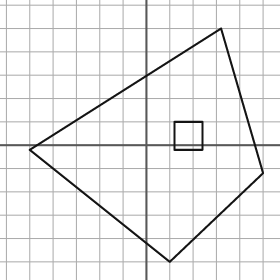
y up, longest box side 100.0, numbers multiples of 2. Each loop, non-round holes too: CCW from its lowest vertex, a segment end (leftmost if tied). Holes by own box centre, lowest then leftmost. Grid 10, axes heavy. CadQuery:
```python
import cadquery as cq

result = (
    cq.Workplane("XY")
    .moveTo(10.0, -50.0)
    .lineTo(50.0, -12.0)
    .lineTo(32.0, 50.0)
    .lineTo(-50.0, -2.0)
    .close()
    .moveTo(12.0, -2.0)
    .lineTo(24.0, -2.0)
    .lineTo(24.0, 10.0)
    .lineTo(12.0, 10.0)
    .close()
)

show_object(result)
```